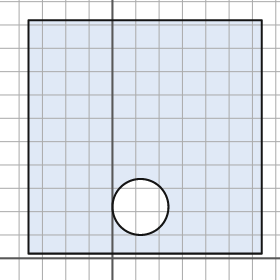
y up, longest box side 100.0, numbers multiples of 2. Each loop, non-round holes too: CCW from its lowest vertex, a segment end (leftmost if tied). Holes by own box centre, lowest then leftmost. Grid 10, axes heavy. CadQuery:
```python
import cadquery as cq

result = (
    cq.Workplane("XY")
    .moveTo(-36.0, 2.0)
    .lineTo(64.0, 2.0)
    .lineTo(64.0, 102.0)
    .lineTo(-36.0, 102.0)
    .close()
    .moveTo(12.0, 22.0)
    .circle(12.0)
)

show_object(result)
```